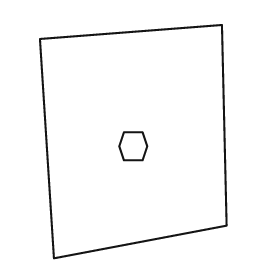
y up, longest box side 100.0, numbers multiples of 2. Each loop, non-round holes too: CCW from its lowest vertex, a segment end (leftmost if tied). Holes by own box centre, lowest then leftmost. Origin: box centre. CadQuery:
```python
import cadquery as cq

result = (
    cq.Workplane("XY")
    .moveTo(-34.0, -50.0)
    .lineTo(40.0, -36.0)
    .lineTo(38.0, 50.0)
    .lineTo(-40.0, 44.0)
    .close()
    .moveTo(-4.0, -8.0)
    .lineTo(4.0, -8.0)
    .lineTo(6.0, -2.0)
    .lineTo(4.0, 4.0)
    .lineTo(-4.0, 4.0)
    .lineTo(-6.0, -2.0)
    .close()
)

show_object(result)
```